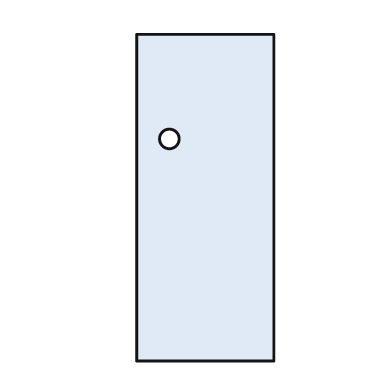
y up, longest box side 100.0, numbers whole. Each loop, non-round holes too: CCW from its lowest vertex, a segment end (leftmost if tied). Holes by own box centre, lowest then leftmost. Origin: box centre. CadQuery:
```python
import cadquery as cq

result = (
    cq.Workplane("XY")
    .moveTo(-21.0, -50.0)
    .lineTo(21.0, -50.0)
    .lineTo(21.0, 50.0)
    .lineTo(-21.0, 50.0)
    .close()
    .moveTo(-11.0, 18.0)
    .circle(3.0)
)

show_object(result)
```